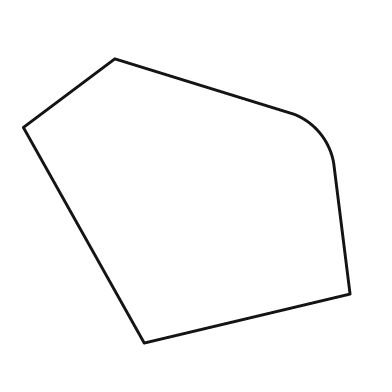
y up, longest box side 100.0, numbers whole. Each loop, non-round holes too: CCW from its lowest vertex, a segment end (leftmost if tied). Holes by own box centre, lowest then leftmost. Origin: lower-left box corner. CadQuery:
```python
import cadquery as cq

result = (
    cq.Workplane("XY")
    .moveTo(37.0, 0.0)
    .lineTo(100.0, 15.0)
    .lineTo(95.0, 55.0)
    .threePointArc((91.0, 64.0), (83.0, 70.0))
    .lineTo(28.0, 87.0)
    .lineTo(0.0, 66.0)
    .close()
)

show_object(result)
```